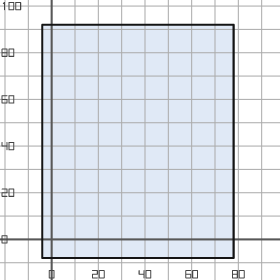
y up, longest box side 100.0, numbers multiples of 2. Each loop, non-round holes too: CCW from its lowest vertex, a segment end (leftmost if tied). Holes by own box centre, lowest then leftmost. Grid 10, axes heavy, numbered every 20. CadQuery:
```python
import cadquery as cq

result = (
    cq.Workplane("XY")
    .moveTo(-4.0, -8.0)
    .lineTo(78.0, -8.0)
    .lineTo(78.0, 92.0)
    .lineTo(-4.0, 92.0)
    .close()
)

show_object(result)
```